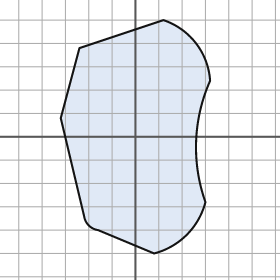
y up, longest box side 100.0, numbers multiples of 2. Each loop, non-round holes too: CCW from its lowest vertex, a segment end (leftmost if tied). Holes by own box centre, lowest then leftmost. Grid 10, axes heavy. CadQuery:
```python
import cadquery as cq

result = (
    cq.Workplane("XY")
    .moveTo(8.0, -50.0)
    .threePointArc((22.0, -42.0), (30.0, -28.0))
    .threePointArc((26.0, -2.0), (32.0, 24.0))
    .threePointArc((26.0, 40.0), (12.0, 50.0))
    .lineTo(-24.0, 38.0)
    .lineTo(-32.0, 8.0)
    .lineTo(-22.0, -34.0)
    .threePointArc((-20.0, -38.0), (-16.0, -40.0))
    .close()
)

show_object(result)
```